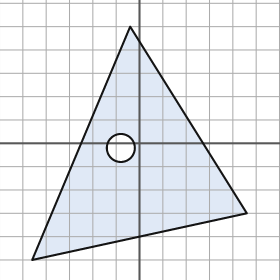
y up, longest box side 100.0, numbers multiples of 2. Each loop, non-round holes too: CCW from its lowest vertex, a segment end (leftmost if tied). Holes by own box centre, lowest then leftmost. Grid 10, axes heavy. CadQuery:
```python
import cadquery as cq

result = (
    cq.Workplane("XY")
    .moveTo(-46.0, -50.0)
    .lineTo(46.0, -30.0)
    .lineTo(-4.0, 50.0)
    .close()
    .moveTo(-8.0, -2.0)
    .circle(6.0)
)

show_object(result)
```